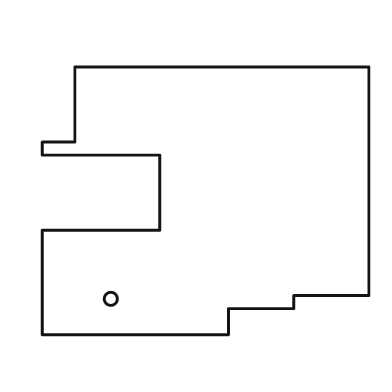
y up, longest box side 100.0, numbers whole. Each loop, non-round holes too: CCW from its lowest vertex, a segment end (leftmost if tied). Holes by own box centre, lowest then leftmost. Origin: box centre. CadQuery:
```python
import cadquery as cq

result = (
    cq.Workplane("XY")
    .moveTo(-50.0, -41.0)
    .lineTo(7.0, -41.0)
    .lineTo(7.0, -33.0)
    .lineTo(27.0, -33.0)
    .lineTo(27.0, -29.0)
    .lineTo(50.0, -29.0)
    .lineTo(50.0, 41.0)
    .lineTo(-40.0, 41.0)
    .lineTo(-40.0, 18.0)
    .lineTo(-50.0, 18.0)
    .lineTo(-50.0, 14.0)
    .lineTo(-14.0, 14.0)
    .lineTo(-14.0, -9.0)
    .lineTo(-50.0, -9.0)
    .close()
    .moveTo(-29.0, -30.0)
    .circle(2.0)
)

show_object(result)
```